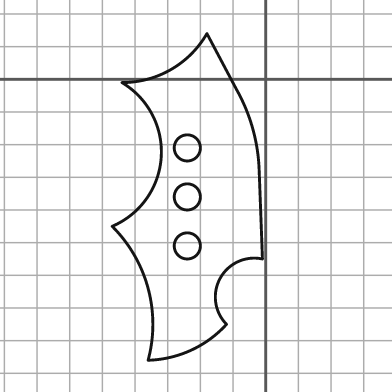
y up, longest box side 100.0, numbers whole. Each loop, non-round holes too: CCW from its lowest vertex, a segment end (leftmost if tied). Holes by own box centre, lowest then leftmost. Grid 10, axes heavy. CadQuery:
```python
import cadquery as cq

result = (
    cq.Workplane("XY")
    .moveTo(-36.0, -86.0)
    .threePointArc((-23.0, -83.0), (-12.0, -75.0))
    .threePointArc((-14.0, -61.0), (-1.0, -55.0))
    .lineTo(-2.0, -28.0)
    .threePointArc((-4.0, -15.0), (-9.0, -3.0))
    .lineTo(-18.0, 14.0)
    .threePointArc((-29.0, 3.0), (-44.0, -1.0))
    .threePointArc((-32.0, -24.0), (-47.0, -45.0))
    .threePointArc((-36.0, -64.0), (-36.0, -86.0))
    .close()
    .moveTo(-24.0, -51.0)
    .circle(4.0)
    .moveTo(-24.0, -36.0)
    .circle(4.0)
    .moveTo(-24.0, -21.0)
    .circle(4.0)
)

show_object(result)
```